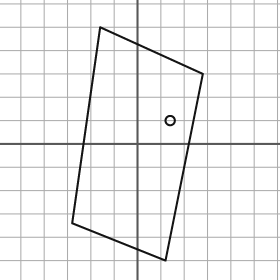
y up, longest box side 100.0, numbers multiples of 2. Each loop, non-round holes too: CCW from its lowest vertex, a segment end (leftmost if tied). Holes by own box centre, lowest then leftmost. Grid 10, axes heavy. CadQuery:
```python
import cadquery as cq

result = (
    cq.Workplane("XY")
    .moveTo(12.0, -50.0)
    .lineTo(28.0, 30.0)
    .lineTo(-16.0, 50.0)
    .lineTo(-28.0, -34.0)
    .close()
    .moveTo(14.0, 10.0)
    .circle(2.0)
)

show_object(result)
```